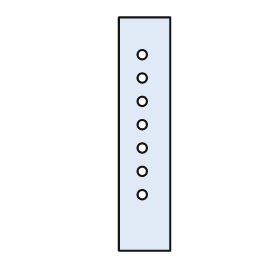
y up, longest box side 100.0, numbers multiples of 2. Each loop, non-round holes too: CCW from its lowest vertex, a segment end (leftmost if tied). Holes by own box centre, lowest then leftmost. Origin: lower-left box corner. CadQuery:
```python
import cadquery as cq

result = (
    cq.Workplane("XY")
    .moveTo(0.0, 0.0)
    .lineTo(22.0, 0.0)
    .lineTo(22.0, 100.0)
    .lineTo(0.0, 100.0)
    .close()
    .moveTo(10.0, 24.0)
    .circle(2.0)
    .moveTo(10.0, 34.0)
    .circle(2.0)
    .moveTo(10.0, 44.0)
    .circle(2.0)
    .moveTo(10.0, 54.0)
    .circle(2.0)
    .moveTo(10.0, 64.0)
    .circle(2.0)
    .moveTo(10.0, 74.0)
    .circle(2.0)
    .moveTo(10.0, 84.0)
    .circle(2.0)
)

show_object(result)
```